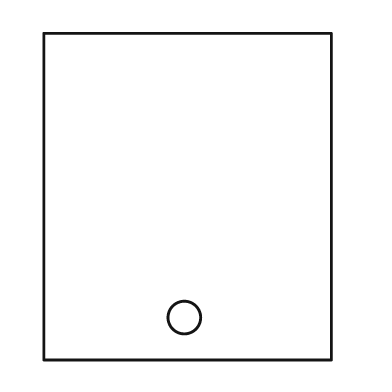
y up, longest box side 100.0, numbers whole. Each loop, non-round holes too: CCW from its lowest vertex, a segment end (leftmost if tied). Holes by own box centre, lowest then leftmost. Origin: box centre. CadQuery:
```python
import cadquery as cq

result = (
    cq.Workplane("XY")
    .moveTo(-44.0, -50.0)
    .lineTo(44.0, -50.0)
    .lineTo(44.0, 50.0)
    .lineTo(-44.0, 50.0)
    .close()
    .moveTo(-1.0, -37.0)
    .circle(5.0)
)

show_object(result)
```